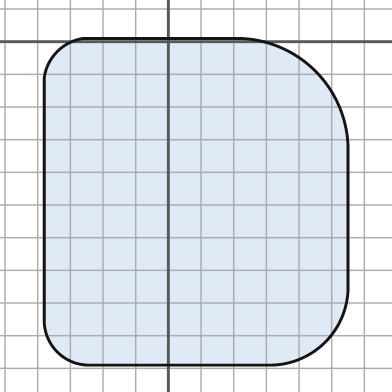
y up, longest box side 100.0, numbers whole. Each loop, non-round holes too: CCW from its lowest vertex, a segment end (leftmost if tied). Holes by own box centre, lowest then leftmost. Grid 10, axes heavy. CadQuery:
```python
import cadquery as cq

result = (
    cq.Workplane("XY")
    .moveTo(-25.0, -99.0)
    .lineTo(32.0, -99.0)
    .threePointArc((48.0, -92.0), (55.0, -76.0))
    .lineTo(55.0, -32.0)
    .threePointArc((45.0, -9.0), (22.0, 1.0))
    .lineTo(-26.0, 1.0)
    .threePointArc((-34.0, -3.0), (-38.0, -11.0))
    .lineTo(-38.0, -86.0)
    .threePointArc((-34.0, -95.0), (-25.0, -99.0))
    .close()
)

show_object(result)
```